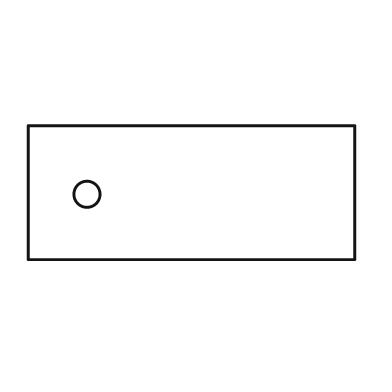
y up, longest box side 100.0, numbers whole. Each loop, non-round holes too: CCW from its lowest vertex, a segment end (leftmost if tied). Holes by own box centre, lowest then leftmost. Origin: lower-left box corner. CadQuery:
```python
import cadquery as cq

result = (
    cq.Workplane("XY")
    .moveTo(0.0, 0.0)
    .lineTo(100.0, 0.0)
    .lineTo(100.0, 41.0)
    .lineTo(0.0, 41.0)
    .close()
    .moveTo(18.0, 20.0)
    .circle(4.0)
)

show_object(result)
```